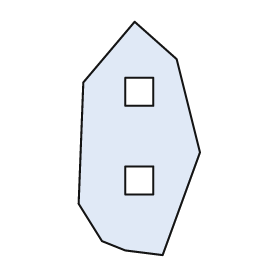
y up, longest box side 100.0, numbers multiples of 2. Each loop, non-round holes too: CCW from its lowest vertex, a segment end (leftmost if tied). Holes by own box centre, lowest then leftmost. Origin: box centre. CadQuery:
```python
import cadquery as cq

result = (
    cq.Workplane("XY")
    .moveTo(10.0, -50.0)
    .lineTo(26.0, -6.0)
    .lineTo(16.0, 34.0)
    .lineTo(-2.0, 50.0)
    .lineTo(-24.0, 24.0)
    .lineTo(-26.0, -28.0)
    .lineTo(-16.0, -44.0)
    .lineTo(-6.0, -48.0)
    .close()
    .moveTo(-6.0, -24.0)
    .lineTo(6.0, -24.0)
    .lineTo(6.0, -12.0)
    .lineTo(-6.0, -12.0)
    .close()
    .moveTo(-6.0, 14.0)
    .lineTo(6.0, 14.0)
    .lineTo(6.0, 26.0)
    .lineTo(-6.0, 26.0)
    .close()
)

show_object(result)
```